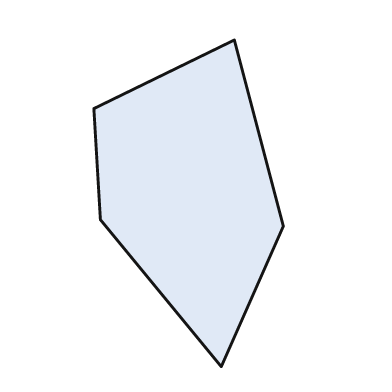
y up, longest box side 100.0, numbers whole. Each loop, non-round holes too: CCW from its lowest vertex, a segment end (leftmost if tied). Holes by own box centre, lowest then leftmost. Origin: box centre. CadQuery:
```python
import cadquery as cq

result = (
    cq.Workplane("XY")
    .moveTo(10.0, -50.0)
    .lineTo(29.0, -7.0)
    .lineTo(14.0, 50.0)
    .lineTo(-29.0, 29.0)
    .lineTo(-27.0, -5.0)
    .close()
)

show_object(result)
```